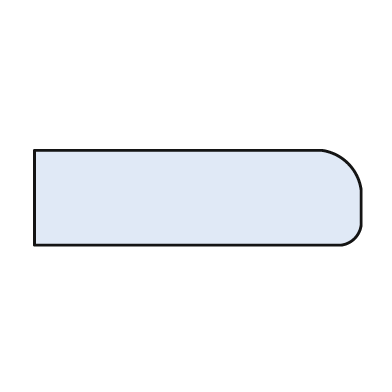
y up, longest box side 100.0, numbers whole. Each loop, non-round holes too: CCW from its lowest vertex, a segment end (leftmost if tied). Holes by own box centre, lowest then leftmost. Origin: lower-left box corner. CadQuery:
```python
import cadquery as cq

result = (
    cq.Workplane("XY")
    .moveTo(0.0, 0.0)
    .lineTo(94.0, 0.0)
    .threePointArc((98.0, 2.0), (100.0, 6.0))
    .lineTo(100.0, 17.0)
    .threePointArc((96.0, 25.0), (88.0, 29.0))
    .lineTo(0.0, 29.0)
    .close()
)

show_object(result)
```